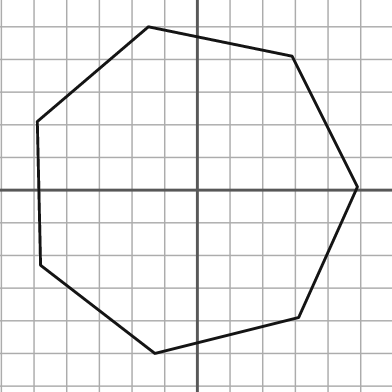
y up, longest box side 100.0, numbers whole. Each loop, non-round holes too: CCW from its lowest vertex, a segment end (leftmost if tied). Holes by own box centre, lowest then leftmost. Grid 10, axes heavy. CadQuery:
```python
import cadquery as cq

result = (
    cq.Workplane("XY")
    .moveTo(-13.0, -50.0)
    .lineTo(31.0, -39.0)
    .lineTo(49.0, 1.0)
    .lineTo(29.0, 41.0)
    .lineTo(-15.0, 50.0)
    .lineTo(-49.0, 21.0)
    .lineTo(-48.0, -23.0)
    .close()
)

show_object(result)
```